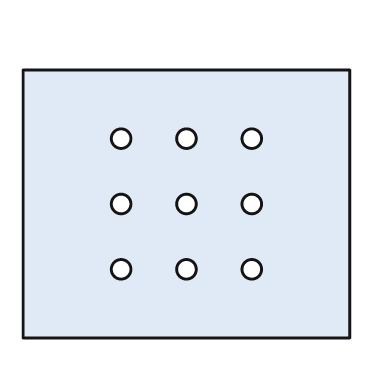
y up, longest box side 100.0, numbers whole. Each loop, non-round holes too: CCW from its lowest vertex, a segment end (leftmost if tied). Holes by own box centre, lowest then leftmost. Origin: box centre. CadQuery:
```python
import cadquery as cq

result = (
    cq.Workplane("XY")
    .moveTo(-50.0, -41.0)
    .lineTo(50.0, -41.0)
    .lineTo(50.0, 41.0)
    .lineTo(-50.0, 41.0)
    .close()
    .moveTo(-20.0, -20.0)
    .circle(3.0)
    .moveTo(0.0, -20.0)
    .circle(3.0)
    .moveTo(20.0, -20.0)
    .circle(3.0)
    .moveTo(-20.0, 0.0)
    .circle(3.0)
    .moveTo(0.0, 0.0)
    .circle(3.0)
    .moveTo(20.0, 0.0)
    .circle(3.0)
    .moveTo(-20.0, 20.0)
    .circle(3.0)
    .moveTo(0.0, 20.0)
    .circle(3.0)
    .moveTo(20.0, 20.0)
    .circle(3.0)
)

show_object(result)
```